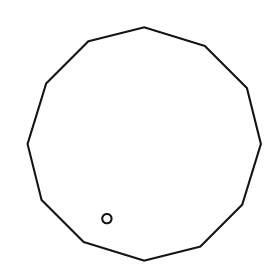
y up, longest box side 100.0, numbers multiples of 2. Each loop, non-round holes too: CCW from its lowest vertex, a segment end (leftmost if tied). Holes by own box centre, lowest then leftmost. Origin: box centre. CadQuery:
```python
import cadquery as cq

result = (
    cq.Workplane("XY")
    .moveTo(0.0, -50.0)
    .lineTo(24.0, -44.0)
    .lineTo(42.0, -26.0)
    .lineTo(50.0, 0.0)
    .lineTo(44.0, 24.0)
    .lineTo(26.0, 42.0)
    .lineTo(0.0, 50.0)
    .lineTo(-24.0, 44.0)
    .lineTo(-42.0, 26.0)
    .lineTo(-50.0, 0.0)
    .lineTo(-44.0, -24.0)
    .lineTo(-26.0, -42.0)
    .close()
    .moveTo(-16.0, -32.0)
    .circle(2.0)
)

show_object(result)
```